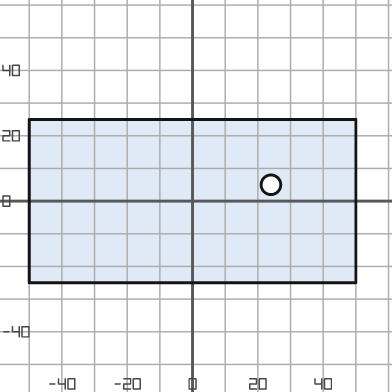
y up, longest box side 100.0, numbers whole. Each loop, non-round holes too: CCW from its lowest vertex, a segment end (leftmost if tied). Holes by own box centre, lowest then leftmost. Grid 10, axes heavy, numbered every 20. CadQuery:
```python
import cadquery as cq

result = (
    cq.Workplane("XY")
    .moveTo(-50.0, -25.0)
    .lineTo(50.0, -25.0)
    .lineTo(50.0, 25.0)
    .lineTo(-50.0, 25.0)
    .close()
    .moveTo(24.0, 5.0)
    .circle(3.0)
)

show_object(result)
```